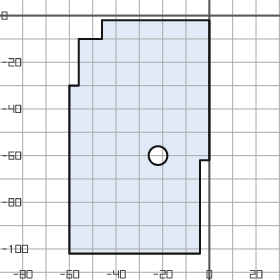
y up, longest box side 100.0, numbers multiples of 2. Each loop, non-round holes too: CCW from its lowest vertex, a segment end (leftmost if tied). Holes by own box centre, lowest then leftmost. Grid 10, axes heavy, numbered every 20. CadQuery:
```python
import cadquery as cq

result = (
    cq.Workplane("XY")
    .moveTo(-60.0, -102.0)
    .lineTo(-4.0, -102.0)
    .lineTo(-4.0, -62.0)
    .lineTo(0.0, -62.0)
    .lineTo(0.0, -2.0)
    .lineTo(-46.0, -2.0)
    .lineTo(-46.0, -10.0)
    .lineTo(-56.0, -10.0)
    .lineTo(-56.0, -30.0)
    .lineTo(-60.0, -30.0)
    .close()
    .moveTo(-22.0, -60.0)
    .circle(4.0)
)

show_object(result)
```